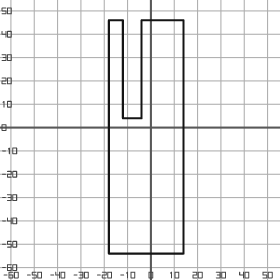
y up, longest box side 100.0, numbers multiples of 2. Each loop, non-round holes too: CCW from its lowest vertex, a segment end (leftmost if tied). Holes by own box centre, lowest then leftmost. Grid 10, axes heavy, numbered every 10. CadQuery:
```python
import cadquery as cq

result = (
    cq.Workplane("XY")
    .moveTo(-18.0, -54.0)
    .lineTo(14.0, -54.0)
    .lineTo(14.0, 46.0)
    .lineTo(-4.0, 46.0)
    .lineTo(-4.0, 4.0)
    .lineTo(-12.0, 4.0)
    .lineTo(-12.0, 46.0)
    .lineTo(-18.0, 46.0)
    .close()
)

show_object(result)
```